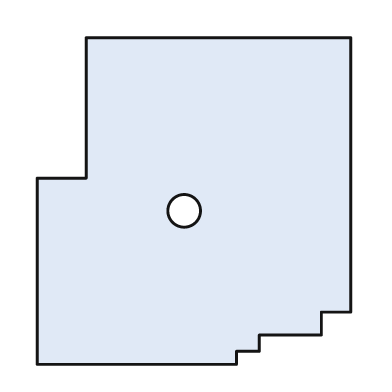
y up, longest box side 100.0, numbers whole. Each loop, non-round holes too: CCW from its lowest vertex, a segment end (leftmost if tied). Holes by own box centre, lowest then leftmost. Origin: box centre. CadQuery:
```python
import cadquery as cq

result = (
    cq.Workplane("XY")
    .moveTo(-48.0, -50.0)
    .lineTo(13.0, -50.0)
    .lineTo(13.0, -46.0)
    .lineTo(20.0, -46.0)
    .lineTo(20.0, -41.0)
    .lineTo(39.0, -41.0)
    .lineTo(39.0, -34.0)
    .lineTo(48.0, -34.0)
    .lineTo(48.0, 50.0)
    .lineTo(-33.0, 50.0)
    .lineTo(-33.0, 7.0)
    .lineTo(-48.0, 7.0)
    .close()
    .moveTo(-3.0, -3.0)
    .circle(5.0)
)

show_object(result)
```